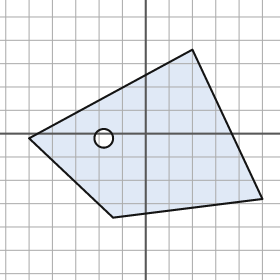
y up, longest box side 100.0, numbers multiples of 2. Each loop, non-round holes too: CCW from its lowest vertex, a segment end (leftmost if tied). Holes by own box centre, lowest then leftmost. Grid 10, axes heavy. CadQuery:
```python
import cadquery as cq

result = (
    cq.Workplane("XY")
    .moveTo(-14.0, -36.0)
    .lineTo(50.0, -28.0)
    .lineTo(20.0, 36.0)
    .lineTo(-50.0, -2.0)
    .close()
    .moveTo(-18.0, -2.0)
    .circle(4.0)
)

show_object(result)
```